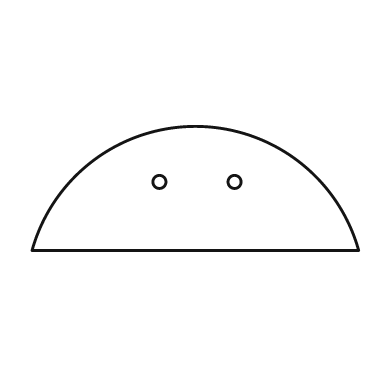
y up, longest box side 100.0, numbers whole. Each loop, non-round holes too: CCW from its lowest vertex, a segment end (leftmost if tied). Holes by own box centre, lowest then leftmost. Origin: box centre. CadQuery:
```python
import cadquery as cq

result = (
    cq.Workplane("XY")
    .moveTo(-50.0, -19.0)
    .lineTo(50.0, -19.0)
    .threePointArc((0.0, 19.0), (-50.0, -19.0))
    .close()
    .moveTo(-11.0, 2.0)
    .circle(2.0)
    .moveTo(12.0, 2.0)
    .circle(2.0)
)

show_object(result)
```